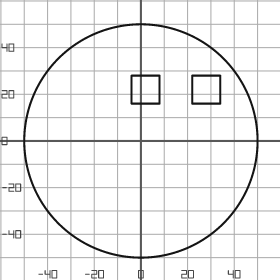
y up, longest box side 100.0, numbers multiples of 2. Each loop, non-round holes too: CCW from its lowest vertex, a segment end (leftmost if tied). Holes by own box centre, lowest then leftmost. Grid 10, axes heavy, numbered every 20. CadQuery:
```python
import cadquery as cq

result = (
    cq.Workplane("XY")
    .moveTo(0.0, 0.0)
    .circle(50.0)
    .moveTo(-4.0, 16.0)
    .lineTo(8.0, 16.0)
    .lineTo(8.0, 28.0)
    .lineTo(-4.0, 28.0)
    .close()
    .moveTo(22.0, 16.0)
    .lineTo(34.0, 16.0)
    .lineTo(34.0, 28.0)
    .lineTo(22.0, 28.0)
    .close()
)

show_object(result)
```